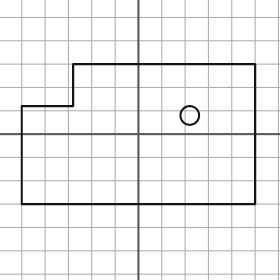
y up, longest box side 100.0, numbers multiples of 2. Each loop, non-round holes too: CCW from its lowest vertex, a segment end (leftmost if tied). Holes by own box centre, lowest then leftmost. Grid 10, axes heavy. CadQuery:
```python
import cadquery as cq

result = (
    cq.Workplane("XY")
    .moveTo(-50.0, -30.0)
    .lineTo(50.0, -30.0)
    .lineTo(50.0, 30.0)
    .lineTo(-28.0, 30.0)
    .lineTo(-28.0, 12.0)
    .lineTo(-50.0, 12.0)
    .close()
    .moveTo(22.0, 8.0)
    .circle(4.0)
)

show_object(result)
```